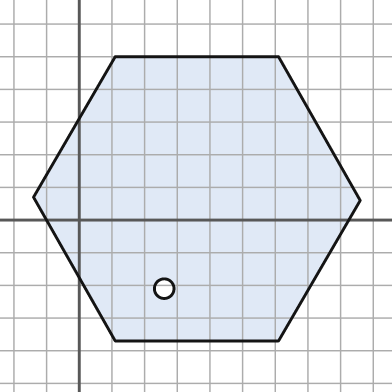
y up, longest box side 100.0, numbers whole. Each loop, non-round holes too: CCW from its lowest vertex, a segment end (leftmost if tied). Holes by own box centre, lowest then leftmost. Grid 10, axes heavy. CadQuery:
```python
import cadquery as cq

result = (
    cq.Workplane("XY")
    .moveTo(11.0, -37.0)
    .lineTo(61.0, -37.0)
    .lineTo(86.0, 6.0)
    .lineTo(61.0, 50.0)
    .lineTo(11.0, 50.0)
    .lineTo(-14.0, 7.0)
    .close()
    .moveTo(26.0, -21.0)
    .circle(3.0)
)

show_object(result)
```